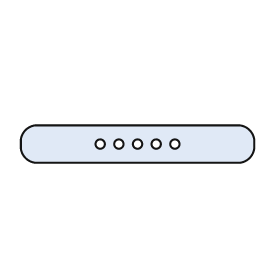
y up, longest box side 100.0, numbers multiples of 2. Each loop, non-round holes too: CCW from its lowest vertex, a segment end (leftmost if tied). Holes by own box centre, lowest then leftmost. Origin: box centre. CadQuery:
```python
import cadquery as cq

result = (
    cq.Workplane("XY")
    .moveTo(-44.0, -8.0)
    .lineTo(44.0, -8.0)
    .threePointArc((48.0, -6.0), (50.0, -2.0))
    .lineTo(50.0, 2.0)
    .threePointArc((48.0, 6.0), (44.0, 8.0))
    .lineTo(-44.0, 8.0)
    .threePointArc((-48.0, 6.0), (-50.0, 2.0))
    .lineTo(-50.0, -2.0)
    .threePointArc((-48.0, -6.0), (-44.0, -8.0))
    .close()
    .moveTo(-16.0, 0.0)
    .circle(2.0)
    .moveTo(-8.0, 0.0)
    .circle(2.0)
    .moveTo(0.0, 0.0)
    .circle(2.0)
    .moveTo(8.0, 0.0)
    .circle(2.0)
    .moveTo(16.0, 0.0)
    .circle(2.0)
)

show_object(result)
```